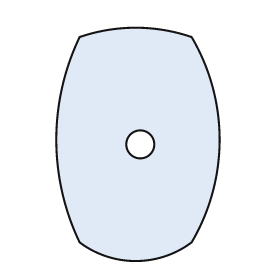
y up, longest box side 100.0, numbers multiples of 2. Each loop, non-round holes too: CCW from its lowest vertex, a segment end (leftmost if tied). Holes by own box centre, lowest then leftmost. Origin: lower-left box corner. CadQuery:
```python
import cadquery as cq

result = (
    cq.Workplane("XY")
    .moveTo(10.0, 8.0)
    .threePointArc((34.0, 0.0), (58.0, 8.0))
    .threePointArc((70.0, 52.0), (58.0, 96.0))
    .threePointArc((34.0, 100.0), (10.0, 96.0))
    .threePointArc((0.0, 52.0), (10.0, 8.0))
    .close()
    .moveTo(36.0, 50.0)
    .circle(6.0)
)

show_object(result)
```